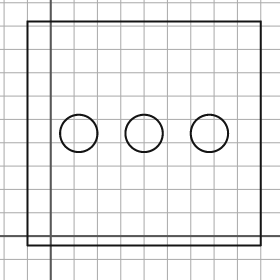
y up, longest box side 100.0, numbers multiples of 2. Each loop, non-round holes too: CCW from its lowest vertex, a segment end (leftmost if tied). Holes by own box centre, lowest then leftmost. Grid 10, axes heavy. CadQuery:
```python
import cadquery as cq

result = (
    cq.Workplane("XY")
    .moveTo(-10.0, -4.0)
    .lineTo(90.0, -4.0)
    .lineTo(90.0, 92.0)
    .lineTo(-10.0, 92.0)
    .close()
    .moveTo(12.0, 44.0)
    .circle(8.0)
    .moveTo(40.0, 44.0)
    .circle(8.0)
    .moveTo(68.0, 44.0)
    .circle(8.0)
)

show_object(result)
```